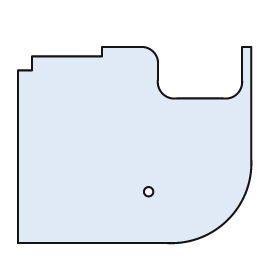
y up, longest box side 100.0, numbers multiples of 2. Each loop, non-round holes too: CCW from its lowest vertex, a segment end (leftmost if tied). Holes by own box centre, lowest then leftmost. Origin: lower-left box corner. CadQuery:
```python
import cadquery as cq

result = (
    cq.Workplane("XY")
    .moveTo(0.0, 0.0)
    .lineTo(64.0, 0.0)
    .threePointArc((90.0, 10.0), (100.0, 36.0))
    .lineTo(100.0, 84.0)
    .lineTo(96.0, 84.0)
    .lineTo(96.0, 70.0)
    .threePointArc((94.0, 64.0), (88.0, 62.0))
    .lineTo(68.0, 62.0)
    .threePointArc((62.0, 64.0), (60.0, 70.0))
    .lineTo(60.0, 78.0)
    .threePointArc((58.0, 82.0), (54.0, 84.0))
    .lineTo(36.0, 84.0)
    .lineTo(36.0, 80.0)
    .lineTo(6.0, 80.0)
    .lineTo(6.0, 74.0)
    .lineTo(0.0, 74.0)
    .close()
    .moveTo(56.0, 22.0)
    .circle(2.0)
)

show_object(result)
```